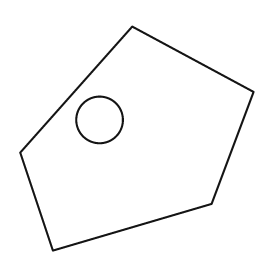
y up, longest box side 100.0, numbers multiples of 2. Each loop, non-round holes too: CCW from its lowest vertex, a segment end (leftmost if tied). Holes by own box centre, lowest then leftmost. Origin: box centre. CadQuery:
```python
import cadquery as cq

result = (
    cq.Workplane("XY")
    .moveTo(-36.0, -48.0)
    .lineTo(32.0, -28.0)
    .lineTo(50.0, 20.0)
    .lineTo(-2.0, 48.0)
    .lineTo(-50.0, -6.0)
    .close()
    .moveTo(-16.0, 8.0)
    .circle(10.0)
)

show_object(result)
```